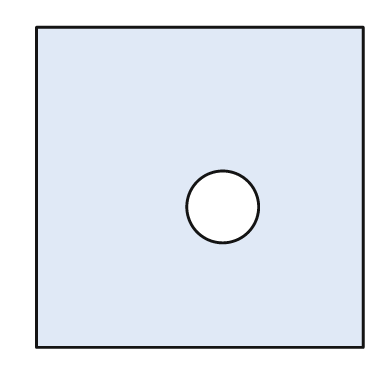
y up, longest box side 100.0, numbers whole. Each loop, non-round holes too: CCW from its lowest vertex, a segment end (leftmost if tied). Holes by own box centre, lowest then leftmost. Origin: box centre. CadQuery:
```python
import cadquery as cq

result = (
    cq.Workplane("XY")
    .moveTo(-50.0, -49.0)
    .lineTo(50.0, -49.0)
    .lineTo(50.0, 49.0)
    .lineTo(-50.0, 49.0)
    .close()
    .moveTo(7.0, -6.0)
    .circle(11.0)
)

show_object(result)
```